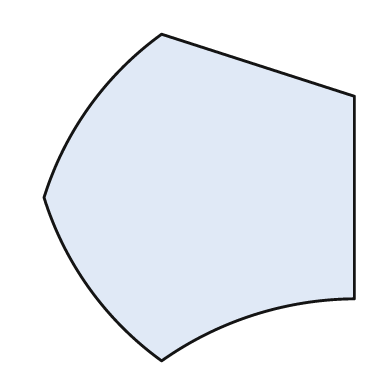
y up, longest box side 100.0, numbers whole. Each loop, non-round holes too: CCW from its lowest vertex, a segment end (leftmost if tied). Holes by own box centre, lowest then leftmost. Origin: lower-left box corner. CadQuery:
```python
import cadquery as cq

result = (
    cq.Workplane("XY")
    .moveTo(36.0, 0.0)
    .threePointArc((64.0, 14.0), (95.0, 19.0))
    .lineTo(95.0, 81.0)
    .lineTo(36.0, 100.0)
    .threePointArc((14.0, 78.0), (0.0, 50.0))
    .threePointArc((14.0, 22.0), (36.0, 0.0))
    .close()
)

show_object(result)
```